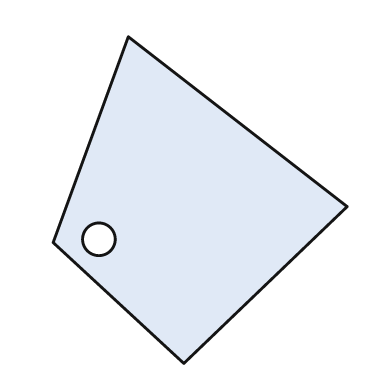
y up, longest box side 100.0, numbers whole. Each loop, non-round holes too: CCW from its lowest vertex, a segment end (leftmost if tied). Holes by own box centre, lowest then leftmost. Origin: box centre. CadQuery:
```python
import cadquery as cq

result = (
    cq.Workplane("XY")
    .moveTo(-5.0, -50.0)
    .lineTo(45.0, -2.0)
    .lineTo(-22.0, 50.0)
    .lineTo(-45.0, -13.0)
    .close()
    .moveTo(-31.0, -12.0)
    .circle(5.0)
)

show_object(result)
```